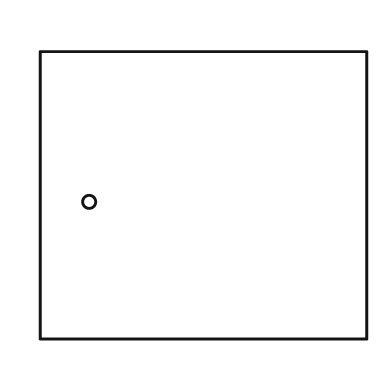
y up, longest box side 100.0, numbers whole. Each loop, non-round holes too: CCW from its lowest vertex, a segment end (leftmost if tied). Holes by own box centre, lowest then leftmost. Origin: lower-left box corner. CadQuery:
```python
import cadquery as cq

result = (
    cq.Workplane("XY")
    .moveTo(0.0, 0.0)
    .lineTo(100.0, 0.0)
    .lineTo(100.0, 88.0)
    .lineTo(0.0, 88.0)
    .close()
    .moveTo(15.0, 42.0)
    .circle(2.0)
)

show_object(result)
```